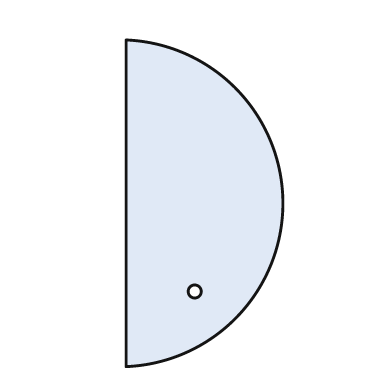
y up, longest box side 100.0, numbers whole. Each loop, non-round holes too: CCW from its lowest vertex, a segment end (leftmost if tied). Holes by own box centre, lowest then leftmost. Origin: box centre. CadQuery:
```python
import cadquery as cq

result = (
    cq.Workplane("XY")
    .moveTo(-24.0, -50.0)
    .threePointArc((24.0, 0.0), (-24.0, 50.0))
    .close()
    .moveTo(-3.0, -27.0)
    .circle(2.0)
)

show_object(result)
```